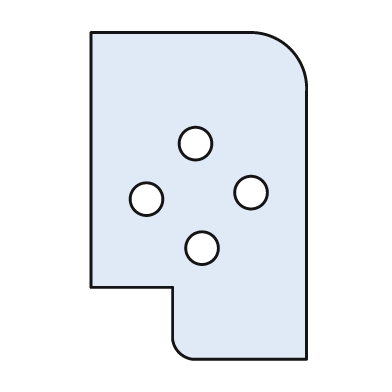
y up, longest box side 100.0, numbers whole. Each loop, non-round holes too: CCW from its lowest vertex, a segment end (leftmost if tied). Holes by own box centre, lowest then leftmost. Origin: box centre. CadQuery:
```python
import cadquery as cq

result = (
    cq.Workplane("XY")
    .moveTo(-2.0, -50.0)
    .lineTo(33.0, -50.0)
    .lineTo(33.0, 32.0)
    .threePointArc((28.0, 45.0), (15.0, 50.0))
    .lineTo(-33.0, 50.0)
    .lineTo(-33.0, -28.0)
    .lineTo(-8.0, -28.0)
    .lineTo(-8.0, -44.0)
    .threePointArc((-6.0, -48.0), (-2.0, -50.0))
    .close()
    .moveTo(1.0, -16.0)
    .circle(5.0)
    .moveTo(-16.0, -1.0)
    .circle(5.0)
    .moveTo(16.0, 1.0)
    .circle(5.0)
    .moveTo(-1.0, 16.0)
    .circle(5.0)
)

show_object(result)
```